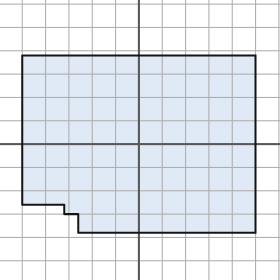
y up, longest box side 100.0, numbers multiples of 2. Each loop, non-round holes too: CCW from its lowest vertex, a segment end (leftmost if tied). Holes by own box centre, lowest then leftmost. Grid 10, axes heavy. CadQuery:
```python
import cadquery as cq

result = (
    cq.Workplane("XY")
    .moveTo(-26.0, -38.0)
    .lineTo(50.0, -38.0)
    .lineTo(50.0, 38.0)
    .lineTo(-50.0, 38.0)
    .lineTo(-50.0, -26.0)
    .lineTo(-32.0, -26.0)
    .lineTo(-32.0, -30.0)
    .lineTo(-26.0, -30.0)
    .close()
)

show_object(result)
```